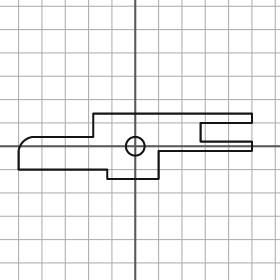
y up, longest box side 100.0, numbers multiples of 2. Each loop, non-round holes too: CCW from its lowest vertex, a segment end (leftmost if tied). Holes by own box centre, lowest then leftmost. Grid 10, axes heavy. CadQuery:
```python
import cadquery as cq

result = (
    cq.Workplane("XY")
    .moveTo(-12.0, -14.0)
    .lineTo(10.0, -14.0)
    .lineTo(10.0, -2.0)
    .lineTo(50.0, -2.0)
    .lineTo(50.0, 2.0)
    .lineTo(28.0, 2.0)
    .lineTo(28.0, 10.0)
    .lineTo(50.0, 10.0)
    .lineTo(50.0, 14.0)
    .lineTo(-18.0, 14.0)
    .lineTo(-18.0, 4.0)
    .lineTo(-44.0, 4.0)
    .threePointArc((-48.0, 2.0), (-50.0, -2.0))
    .lineTo(-50.0, -10.0)
    .lineTo(-12.0, -10.0)
    .close()
    .moveTo(0.0, 0.0)
    .circle(4.0)
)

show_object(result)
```